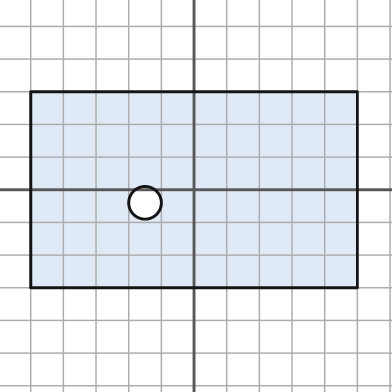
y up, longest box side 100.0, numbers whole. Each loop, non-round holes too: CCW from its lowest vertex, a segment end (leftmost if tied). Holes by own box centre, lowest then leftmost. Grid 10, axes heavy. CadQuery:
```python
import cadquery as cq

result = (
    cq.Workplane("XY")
    .moveTo(-50.0, -30.0)
    .lineTo(50.0, -30.0)
    .lineTo(50.0, 30.0)
    .lineTo(-50.0, 30.0)
    .close()
    .moveTo(-15.0, -4.0)
    .circle(5.0)
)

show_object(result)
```